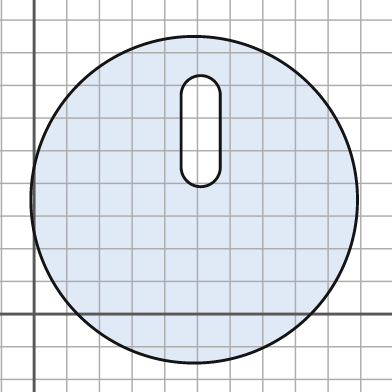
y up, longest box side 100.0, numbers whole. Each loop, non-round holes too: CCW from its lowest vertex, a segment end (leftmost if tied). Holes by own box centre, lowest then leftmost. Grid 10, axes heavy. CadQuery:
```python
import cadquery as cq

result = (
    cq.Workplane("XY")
    .moveTo(49.0, 35.0)
    .circle(50.0)
    .moveTo(45.0, 45.0)
    .threePointArc((51.0, 39.0), (57.0, 45.0))
    .lineTo(57.0, 67.0)
    .threePointArc((51.0, 73.0), (45.0, 67.0))
    .close()
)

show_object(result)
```